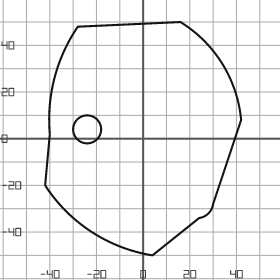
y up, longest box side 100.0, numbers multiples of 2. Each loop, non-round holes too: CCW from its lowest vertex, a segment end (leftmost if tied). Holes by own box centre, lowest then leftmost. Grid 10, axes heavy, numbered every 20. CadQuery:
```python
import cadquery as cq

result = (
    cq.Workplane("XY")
    .moveTo(4.0, -50.0)
    .lineTo(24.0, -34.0)
    .threePointArc((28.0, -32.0), (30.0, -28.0))
    .lineTo(42.0, 8.0)
    .threePointArc((34.0, 32.0), (16.0, 50.0))
    .lineTo(-28.0, 48.0)
    .threePointArc((-38.0, 26.0), (-40.0, 2.0))
    .lineTo(-42.0, -20.0)
    .threePointArc((-22.0, -40.0), (4.0, -50.0))
    .close()
    .moveTo(-24.0, 4.0)
    .circle(6.0)
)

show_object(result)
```